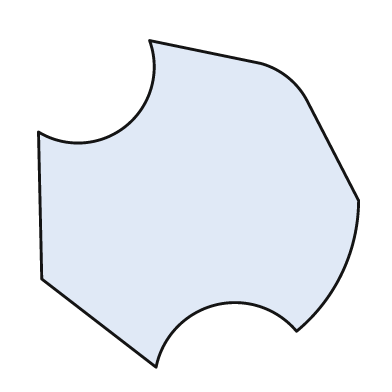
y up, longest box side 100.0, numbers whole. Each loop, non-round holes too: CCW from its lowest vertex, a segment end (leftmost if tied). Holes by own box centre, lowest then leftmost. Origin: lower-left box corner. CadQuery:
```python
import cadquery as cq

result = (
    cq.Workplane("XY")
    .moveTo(36.0, 0.0)
    .threePointArc((54.0, 19.0), (79.0, 11.0))
    .threePointArc((93.0, 29.0), (98.0, 51.0))
    .lineTo(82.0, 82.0)
    .threePointArc((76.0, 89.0), (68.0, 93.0))
    .lineTo(34.0, 100.0)
    .threePointArc((27.0, 74.0), (0.0, 72.0))
    .lineTo(1.0, 27.0)
    .close()
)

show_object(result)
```